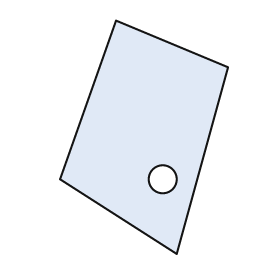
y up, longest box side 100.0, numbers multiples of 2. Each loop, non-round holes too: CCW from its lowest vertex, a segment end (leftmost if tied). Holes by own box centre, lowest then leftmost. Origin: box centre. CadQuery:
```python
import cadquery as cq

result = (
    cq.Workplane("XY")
    .moveTo(14.0, -50.0)
    .lineTo(36.0, 30.0)
    .lineTo(-12.0, 50.0)
    .lineTo(-36.0, -18.0)
    .close()
    .moveTo(8.0, -18.0)
    .circle(6.0)
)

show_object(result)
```